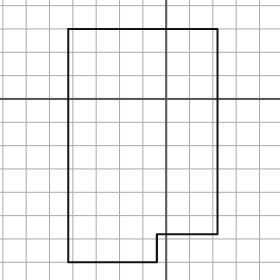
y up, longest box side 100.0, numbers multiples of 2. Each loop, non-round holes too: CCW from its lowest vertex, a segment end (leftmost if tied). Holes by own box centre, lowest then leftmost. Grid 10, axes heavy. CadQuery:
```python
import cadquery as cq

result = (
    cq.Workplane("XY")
    .moveTo(-42.0, -70.0)
    .lineTo(-4.0, -70.0)
    .lineTo(-4.0, -58.0)
    .lineTo(22.0, -58.0)
    .lineTo(22.0, 30.0)
    .lineTo(-42.0, 30.0)
    .close()
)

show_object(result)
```